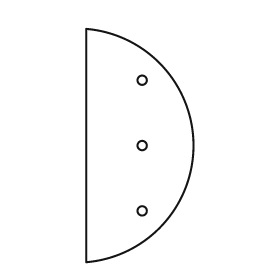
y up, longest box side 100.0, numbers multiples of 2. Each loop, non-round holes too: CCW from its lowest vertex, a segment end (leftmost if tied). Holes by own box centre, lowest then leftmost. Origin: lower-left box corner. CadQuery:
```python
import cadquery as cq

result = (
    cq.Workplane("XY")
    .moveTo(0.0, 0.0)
    .threePointArc((46.0, 50.0), (0.0, 100.0))
    .close()
    .moveTo(24.0, 22.0)
    .circle(2.0)
    .moveTo(24.0, 50.0)
    .circle(2.0)
    .moveTo(24.0, 78.0)
    .circle(2.0)
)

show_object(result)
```